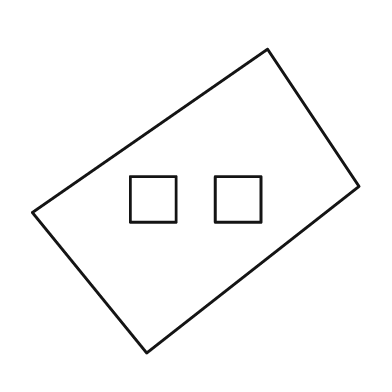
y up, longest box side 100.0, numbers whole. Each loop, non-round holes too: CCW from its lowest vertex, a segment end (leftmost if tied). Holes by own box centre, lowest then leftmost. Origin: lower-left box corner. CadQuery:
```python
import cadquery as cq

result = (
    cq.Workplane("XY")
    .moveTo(35.0, 0.0)
    .lineTo(100.0, 51.0)
    .lineTo(72.0, 93.0)
    .lineTo(0.0, 43.0)
    .close()
    .moveTo(30.0, 40.0)
    .lineTo(44.0, 40.0)
    .lineTo(44.0, 54.0)
    .lineTo(30.0, 54.0)
    .close()
    .moveTo(56.0, 40.0)
    .lineTo(70.0, 40.0)
    .lineTo(70.0, 54.0)
    .lineTo(56.0, 54.0)
    .close()
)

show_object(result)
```